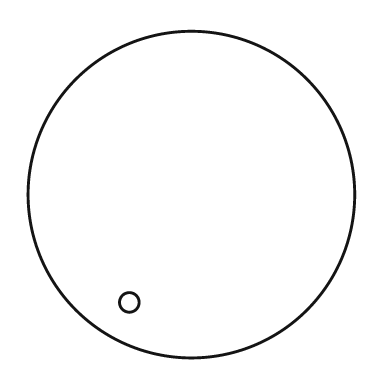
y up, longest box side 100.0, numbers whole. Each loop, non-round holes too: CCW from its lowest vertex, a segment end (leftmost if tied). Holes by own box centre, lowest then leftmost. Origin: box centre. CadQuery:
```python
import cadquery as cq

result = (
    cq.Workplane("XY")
    .moveTo(0.0, 0.0)
    .circle(50.0)
    .moveTo(-19.0, -33.0)
    .circle(3.0)
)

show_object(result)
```